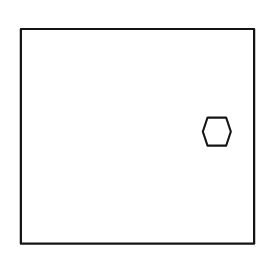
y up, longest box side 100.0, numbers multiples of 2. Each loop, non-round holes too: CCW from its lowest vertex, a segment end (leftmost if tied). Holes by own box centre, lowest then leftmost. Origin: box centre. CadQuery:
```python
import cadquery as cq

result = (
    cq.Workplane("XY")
    .moveTo(-50.0, -46.0)
    .lineTo(50.0, -46.0)
    .lineTo(50.0, 46.0)
    .lineTo(-50.0, 46.0)
    .close()
    .moveTo(30.0, -4.0)
    .lineTo(38.0, -4.0)
    .lineTo(40.0, 2.0)
    .lineTo(38.0, 8.0)
    .lineTo(30.0, 8.0)
    .lineTo(28.0, 2.0)
    .close()
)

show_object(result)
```